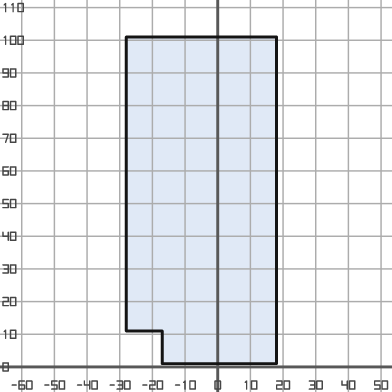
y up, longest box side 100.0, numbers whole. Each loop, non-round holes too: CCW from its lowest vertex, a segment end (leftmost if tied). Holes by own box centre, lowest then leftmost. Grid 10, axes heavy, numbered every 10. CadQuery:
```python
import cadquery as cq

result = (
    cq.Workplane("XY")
    .moveTo(-17.0, 1.0)
    .lineTo(18.0, 1.0)
    .lineTo(18.0, 101.0)
    .lineTo(-28.0, 101.0)
    .lineTo(-28.0, 11.0)
    .lineTo(-17.0, 11.0)
    .close()
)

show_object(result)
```